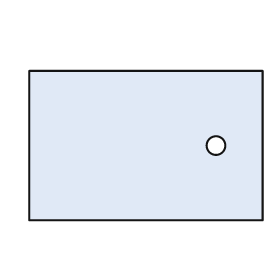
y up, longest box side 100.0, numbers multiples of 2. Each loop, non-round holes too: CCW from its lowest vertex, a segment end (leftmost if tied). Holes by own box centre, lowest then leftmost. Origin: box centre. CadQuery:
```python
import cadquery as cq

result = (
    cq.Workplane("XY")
    .moveTo(-50.0, -32.0)
    .lineTo(50.0, -32.0)
    .lineTo(50.0, 32.0)
    .lineTo(-50.0, 32.0)
    .close()
    .moveTo(30.0, 0.0)
    .circle(4.0)
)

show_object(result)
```